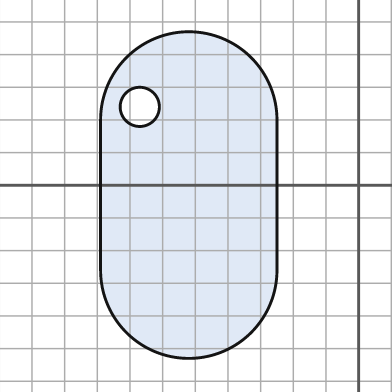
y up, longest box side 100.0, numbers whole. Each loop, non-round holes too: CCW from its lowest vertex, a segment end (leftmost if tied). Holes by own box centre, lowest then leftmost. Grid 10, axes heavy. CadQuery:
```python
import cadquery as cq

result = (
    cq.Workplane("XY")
    .moveTo(-79.0, -26.0)
    .threePointArc((-52.0, -53.0), (-25.0, -26.0))
    .lineTo(-25.0, 20.0)
    .threePointArc((-52.0, 47.0), (-79.0, 20.0))
    .close()
    .moveTo(-67.0, 24.0)
    .circle(6.0)
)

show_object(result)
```